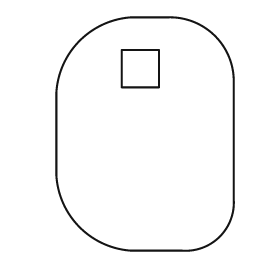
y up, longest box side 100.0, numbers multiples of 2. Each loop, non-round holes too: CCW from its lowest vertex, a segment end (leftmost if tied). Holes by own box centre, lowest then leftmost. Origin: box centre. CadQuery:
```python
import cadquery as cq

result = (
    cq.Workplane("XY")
    .moveTo(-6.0, -50.0)
    .lineTo(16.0, -50.0)
    .threePointArc((32.0, -44.0), (38.0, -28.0))
    .lineTo(38.0, 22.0)
    .threePointArc((30.0, 42.0), (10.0, 50.0))
    .lineTo(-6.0, 50.0)
    .threePointArc((-28.0, 40.0), (-38.0, 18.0))
    .lineTo(-38.0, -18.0)
    .threePointArc((-28.0, -40.0), (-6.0, -50.0))
    .close()
    .moveTo(-10.0, 20.0)
    .lineTo(6.0, 20.0)
    .lineTo(6.0, 36.0)
    .lineTo(-10.0, 36.0)
    .close()
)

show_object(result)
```